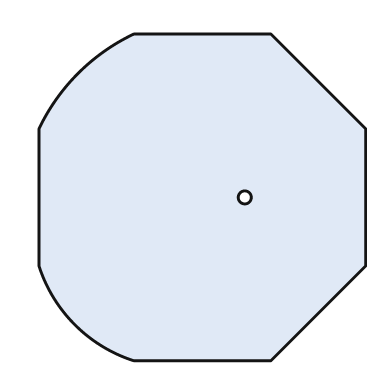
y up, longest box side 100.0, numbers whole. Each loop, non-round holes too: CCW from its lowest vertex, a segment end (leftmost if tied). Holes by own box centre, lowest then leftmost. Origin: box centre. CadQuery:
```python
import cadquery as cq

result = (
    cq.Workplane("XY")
    .moveTo(-21.0, -50.0)
    .lineTo(21.0, -50.0)
    .lineTo(50.0, -21.0)
    .lineTo(50.0, 21.0)
    .lineTo(21.0, 50.0)
    .lineTo(-21.0, 50.0)
    .threePointArc((-38.0, 38.0), (-50.0, 21.0))
    .lineTo(-50.0, -21.0)
    .threePointArc((-39.0, -39.0), (-21.0, -50.0))
    .close()
    .moveTo(13.0, 0.0)
    .circle(2.0)
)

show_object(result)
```